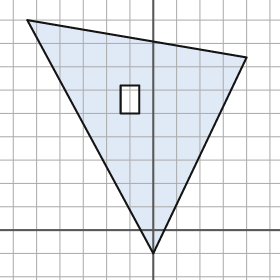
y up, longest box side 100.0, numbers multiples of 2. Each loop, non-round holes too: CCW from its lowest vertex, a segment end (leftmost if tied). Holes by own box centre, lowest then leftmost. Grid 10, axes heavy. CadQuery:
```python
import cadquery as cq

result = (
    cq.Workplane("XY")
    .moveTo(0.0, -10.0)
    .lineTo(40.0, 74.0)
    .lineTo(-54.0, 90.0)
    .close()
    .moveTo(-14.0, 50.0)
    .lineTo(-6.0, 50.0)
    .lineTo(-6.0, 62.0)
    .lineTo(-14.0, 62.0)
    .close()
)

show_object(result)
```